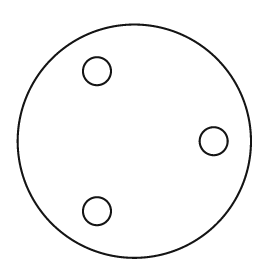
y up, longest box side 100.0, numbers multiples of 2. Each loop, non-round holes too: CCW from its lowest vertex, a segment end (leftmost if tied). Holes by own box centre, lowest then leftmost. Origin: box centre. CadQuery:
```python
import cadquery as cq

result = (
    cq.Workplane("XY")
    .moveTo(0.0, 0.0)
    .circle(50.0)
    .moveTo(-16.0, -30.0)
    .circle(6.0)
    .moveTo(34.0, 0.0)
    .circle(6.0)
    .moveTo(-16.0, 30.0)
    .circle(6.0)
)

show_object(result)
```